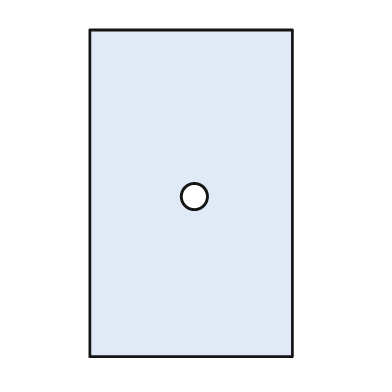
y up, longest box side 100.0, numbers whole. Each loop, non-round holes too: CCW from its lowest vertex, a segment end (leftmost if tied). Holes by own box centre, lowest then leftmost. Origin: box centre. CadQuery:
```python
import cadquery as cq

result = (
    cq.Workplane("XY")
    .moveTo(-31.0, -50.0)
    .lineTo(31.0, -50.0)
    .lineTo(31.0, 50.0)
    .lineTo(-31.0, 50.0)
    .close()
    .moveTo(1.0, -1.0)
    .circle(4.0)
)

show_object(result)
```